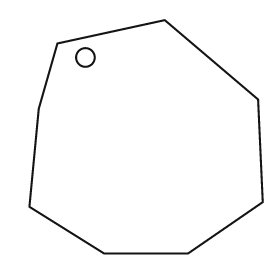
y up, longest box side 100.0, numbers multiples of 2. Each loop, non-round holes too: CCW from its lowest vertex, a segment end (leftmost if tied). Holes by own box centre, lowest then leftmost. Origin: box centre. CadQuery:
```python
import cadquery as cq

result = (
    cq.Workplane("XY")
    .moveTo(-18.0, -50.0)
    .lineTo(18.0, -50.0)
    .lineTo(50.0, -28.0)
    .lineTo(48.0, 16.0)
    .lineTo(8.0, 50.0)
    .lineTo(-38.0, 40.0)
    .lineTo(-46.0, 12.0)
    .lineTo(-50.0, -30.0)
    .close()
    .moveTo(-26.0, 34.0)
    .circle(4.0)
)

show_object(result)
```